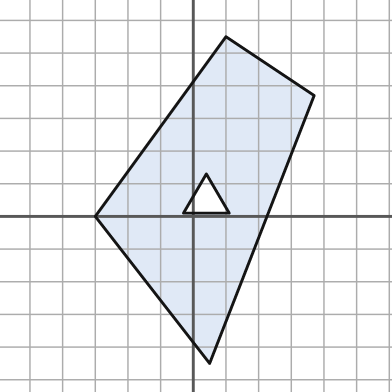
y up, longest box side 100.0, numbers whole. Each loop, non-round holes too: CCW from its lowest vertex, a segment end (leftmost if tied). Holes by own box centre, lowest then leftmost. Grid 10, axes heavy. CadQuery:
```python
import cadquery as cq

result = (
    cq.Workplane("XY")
    .moveTo(5.0, -45.0)
    .lineTo(37.0, 37.0)
    .lineTo(10.0, 55.0)
    .lineTo(-30.0, 0.0)
    .close()
    .moveTo(-3.0, 1.0)
    .lineTo(11.0, 1.0)
    .lineTo(4.0, 13.0)
    .close()
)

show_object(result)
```